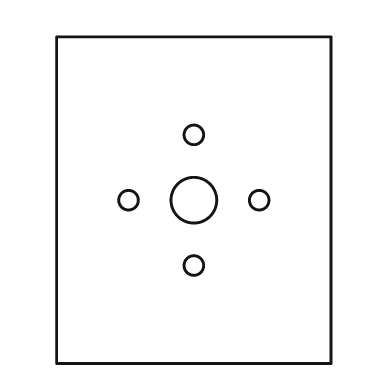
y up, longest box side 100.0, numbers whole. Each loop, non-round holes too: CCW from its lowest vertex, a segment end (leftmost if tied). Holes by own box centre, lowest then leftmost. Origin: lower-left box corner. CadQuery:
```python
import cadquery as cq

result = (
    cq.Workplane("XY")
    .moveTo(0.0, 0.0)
    .lineTo(84.0, 0.0)
    .lineTo(84.0, 100.0)
    .lineTo(0.0, 100.0)
    .close()
    .moveTo(42.0, 30.0)
    .circle(3.0)
    .moveTo(22.0, 50.0)
    .circle(3.0)
    .moveTo(42.0, 50.0)
    .circle(7.0)
    .moveTo(62.0, 50.0)
    .circle(3.0)
    .moveTo(42.0, 70.0)
    .circle(3.0)
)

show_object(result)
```